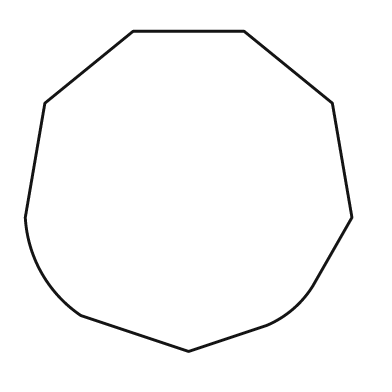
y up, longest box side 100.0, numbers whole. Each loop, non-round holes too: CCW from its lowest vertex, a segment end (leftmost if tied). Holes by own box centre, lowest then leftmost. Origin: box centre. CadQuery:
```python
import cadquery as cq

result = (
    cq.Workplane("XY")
    .moveTo(0.0, -49.0)
    .lineTo(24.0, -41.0)
    .threePointArc((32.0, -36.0), (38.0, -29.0))
    .lineTo(50.0, -8.0)
    .lineTo(44.0, 27.0)
    .lineTo(17.0, 49.0)
    .lineTo(-17.0, 49.0)
    .lineTo(-44.0, 27.0)
    .lineTo(-50.0, -8.0)
    .threePointArc((-45.0, -25.0), (-33.0, -38.0))
    .close()
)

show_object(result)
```